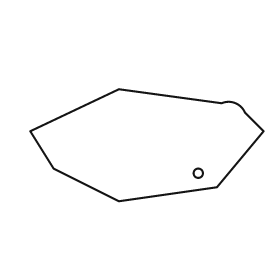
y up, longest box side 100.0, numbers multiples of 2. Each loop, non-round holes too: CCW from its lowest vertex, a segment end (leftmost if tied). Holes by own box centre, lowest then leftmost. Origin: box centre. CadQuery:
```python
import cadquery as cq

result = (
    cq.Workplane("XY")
    .moveTo(-12.0, -24.0)
    .lineTo(30.0, -18.0)
    .lineTo(50.0, 6.0)
    .lineTo(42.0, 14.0)
    .threePointArc((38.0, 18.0), (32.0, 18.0))
    .lineTo(-12.0, 24.0)
    .lineTo(-50.0, 6.0)
    .lineTo(-40.0, -10.0)
    .close()
    .moveTo(22.0, -12.0)
    .circle(2.0)
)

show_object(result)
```